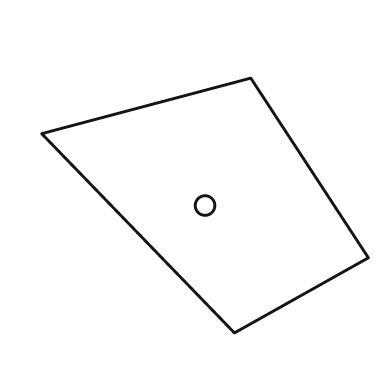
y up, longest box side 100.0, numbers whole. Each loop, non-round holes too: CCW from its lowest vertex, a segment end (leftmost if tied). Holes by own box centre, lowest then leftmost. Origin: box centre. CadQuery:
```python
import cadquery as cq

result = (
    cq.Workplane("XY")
    .moveTo(9.0, -39.0)
    .lineTo(50.0, -16.0)
    .lineTo(14.0, 39.0)
    .lineTo(-50.0, 22.0)
    .close()
    .moveTo(0.0, 0.0)
    .circle(3.0)
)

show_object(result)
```